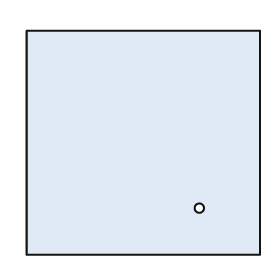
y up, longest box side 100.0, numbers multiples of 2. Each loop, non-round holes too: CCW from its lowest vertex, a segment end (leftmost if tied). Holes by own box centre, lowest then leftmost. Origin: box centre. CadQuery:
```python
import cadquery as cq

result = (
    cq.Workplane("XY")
    .moveTo(-50.0, -48.0)
    .lineTo(50.0, -48.0)
    .lineTo(50.0, 48.0)
    .lineTo(-50.0, 48.0)
    .close()
    .moveTo(24.0, -28.0)
    .circle(2.0)
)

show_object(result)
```